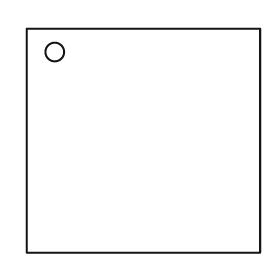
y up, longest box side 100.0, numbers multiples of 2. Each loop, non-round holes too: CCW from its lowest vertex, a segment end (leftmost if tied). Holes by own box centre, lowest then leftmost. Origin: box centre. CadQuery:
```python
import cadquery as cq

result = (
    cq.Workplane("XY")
    .moveTo(-50.0, -48.0)
    .lineTo(50.0, -48.0)
    .lineTo(50.0, 48.0)
    .lineTo(-50.0, 48.0)
    .close()
    .moveTo(-38.0, 38.0)
    .circle(4.0)
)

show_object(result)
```